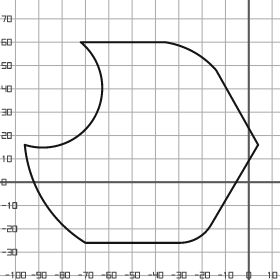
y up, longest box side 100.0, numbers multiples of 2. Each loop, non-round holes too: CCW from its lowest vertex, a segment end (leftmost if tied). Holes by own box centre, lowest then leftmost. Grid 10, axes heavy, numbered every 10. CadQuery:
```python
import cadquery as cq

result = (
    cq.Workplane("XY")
    .moveTo(-70.0, -26.0)
    .lineTo(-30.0, -26.0)
    .threePointArc((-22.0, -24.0), (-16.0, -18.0))
    .lineTo(4.0, 16.0)
    .lineTo(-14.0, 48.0)
    .threePointArc((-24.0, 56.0), (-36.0, 60.0))
    .lineTo(-72.0, 60.0)
    .threePointArc((-66.0, 28.0), (-96.0, 16.0))
    .threePointArc((-88.0, -8.0), (-70.0, -26.0))
    .close()
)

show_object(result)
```